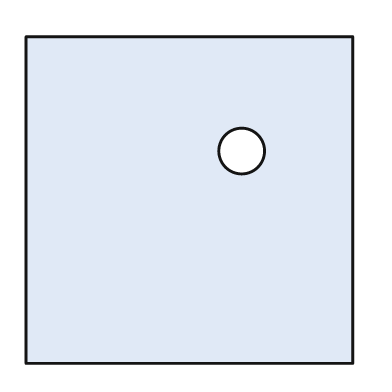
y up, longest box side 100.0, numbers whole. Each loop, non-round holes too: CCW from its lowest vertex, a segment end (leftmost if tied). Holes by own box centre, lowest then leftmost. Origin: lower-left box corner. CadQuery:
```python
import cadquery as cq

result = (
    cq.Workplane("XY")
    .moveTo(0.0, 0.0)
    .lineTo(100.0, 0.0)
    .lineTo(100.0, 100.0)
    .lineTo(0.0, 100.0)
    .close()
    .moveTo(66.0, 65.0)
    .circle(7.0)
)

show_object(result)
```